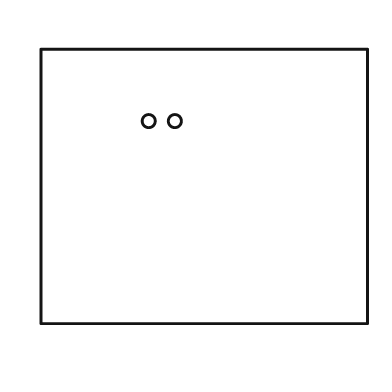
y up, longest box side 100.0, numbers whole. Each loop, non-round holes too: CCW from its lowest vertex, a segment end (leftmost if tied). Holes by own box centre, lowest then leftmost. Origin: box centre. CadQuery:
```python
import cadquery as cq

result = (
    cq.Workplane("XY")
    .moveTo(-50.0, -42.0)
    .lineTo(50.0, -42.0)
    .lineTo(50.0, 42.0)
    .lineTo(-50.0, 42.0)
    .close()
    .moveTo(-17.0, 20.0)
    .circle(2.0)
    .moveTo(-9.0, 20.0)
    .circle(2.0)
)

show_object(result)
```